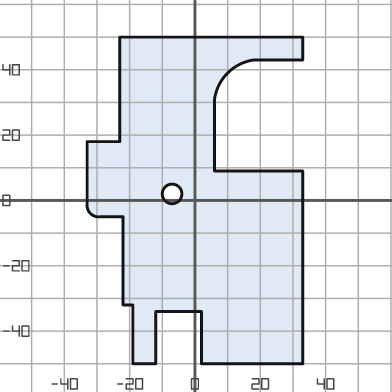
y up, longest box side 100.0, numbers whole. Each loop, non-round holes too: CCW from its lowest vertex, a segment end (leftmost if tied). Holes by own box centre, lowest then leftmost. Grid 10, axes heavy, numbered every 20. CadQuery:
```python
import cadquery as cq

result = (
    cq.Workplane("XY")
    .moveTo(-19.0, -50.0)
    .lineTo(-12.0, -50.0)
    .lineTo(-12.0, -34.0)
    .lineTo(2.0, -34.0)
    .lineTo(2.0, -50.0)
    .lineTo(33.0, -50.0)
    .lineTo(33.0, 9.0)
    .lineTo(6.0, 9.0)
    .lineTo(6.0, 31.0)
    .threePointArc((10.0, 39.0), (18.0, 43.0))
    .lineTo(33.0, 43.0)
    .lineTo(33.0, 50.0)
    .lineTo(-23.0, 50.0)
    .lineTo(-23.0, 18.0)
    .lineTo(-33.0, 18.0)
    .lineTo(-33.0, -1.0)
    .threePointArc((-32.0, -4.0), (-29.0, -5.0))
    .lineTo(-22.0, -5.0)
    .lineTo(-22.0, -32.0)
    .lineTo(-19.0, -32.0)
    .close()
    .moveTo(-7.0, 2.0)
    .circle(3.0)
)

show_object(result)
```